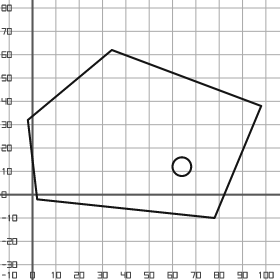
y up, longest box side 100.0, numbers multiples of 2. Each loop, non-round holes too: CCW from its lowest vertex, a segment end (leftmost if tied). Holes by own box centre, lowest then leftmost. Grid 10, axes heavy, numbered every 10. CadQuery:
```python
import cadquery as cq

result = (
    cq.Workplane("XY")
    .moveTo(78.0, -10.0)
    .lineTo(98.0, 38.0)
    .lineTo(34.0, 62.0)
    .lineTo(-2.0, 32.0)
    .lineTo(2.0, -2.0)
    .close()
    .moveTo(64.0, 12.0)
    .circle(4.0)
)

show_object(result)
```